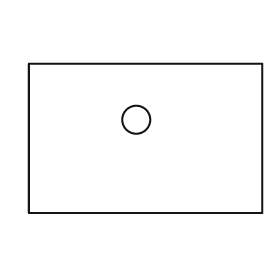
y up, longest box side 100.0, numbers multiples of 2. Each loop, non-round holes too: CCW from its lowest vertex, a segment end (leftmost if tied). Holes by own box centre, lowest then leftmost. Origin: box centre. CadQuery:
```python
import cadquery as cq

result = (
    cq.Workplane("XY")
    .moveTo(-50.0, -32.0)
    .lineTo(50.0, -32.0)
    .lineTo(50.0, 32.0)
    .lineTo(-50.0, 32.0)
    .close()
    .moveTo(-4.0, 8.0)
    .circle(6.0)
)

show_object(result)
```